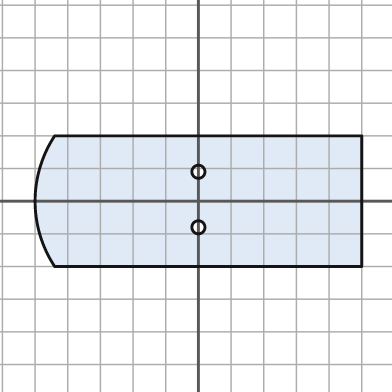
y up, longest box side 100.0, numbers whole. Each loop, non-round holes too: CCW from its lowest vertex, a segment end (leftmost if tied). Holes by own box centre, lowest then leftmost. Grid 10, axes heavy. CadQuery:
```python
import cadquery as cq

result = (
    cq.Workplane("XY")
    .moveTo(-44.0, -20.0)
    .lineTo(50.0, -20.0)
    .lineTo(50.0, 20.0)
    .lineTo(-44.0, 20.0)
    .threePointArc((-50.0, 0.0), (-44.0, -20.0))
    .close()
    .moveTo(0.0, -8.0)
    .circle(2.0)
    .moveTo(0.0, 9.0)
    .circle(2.0)
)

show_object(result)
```